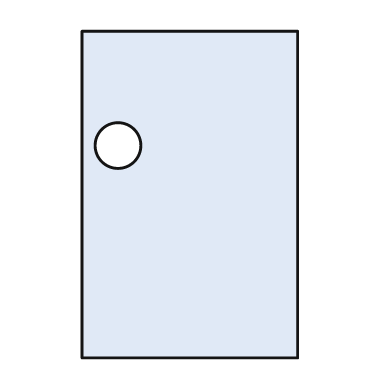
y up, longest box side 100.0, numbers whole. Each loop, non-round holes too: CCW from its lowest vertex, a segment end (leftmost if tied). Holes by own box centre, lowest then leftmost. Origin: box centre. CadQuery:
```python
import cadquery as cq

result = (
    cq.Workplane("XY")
    .moveTo(-33.0, -50.0)
    .lineTo(33.0, -50.0)
    .lineTo(33.0, 50.0)
    .lineTo(-33.0, 50.0)
    .close()
    .moveTo(-22.0, 15.0)
    .circle(7.0)
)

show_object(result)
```